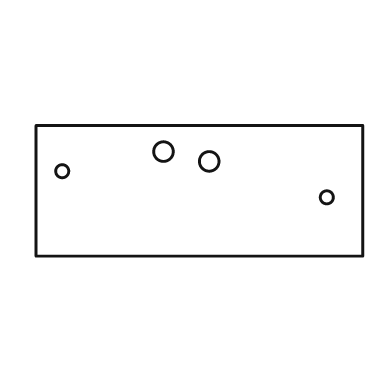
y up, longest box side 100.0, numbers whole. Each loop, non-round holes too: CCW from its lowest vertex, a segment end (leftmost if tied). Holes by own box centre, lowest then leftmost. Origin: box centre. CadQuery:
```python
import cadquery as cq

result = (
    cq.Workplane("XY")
    .moveTo(-50.0, -20.0)
    .lineTo(50.0, -20.0)
    .lineTo(50.0, 20.0)
    .lineTo(-50.0, 20.0)
    .close()
    .moveTo(39.0, -2.0)
    .circle(2.0)
    .moveTo(-42.0, 6.0)
    .circle(2.0)
    .moveTo(3.0, 9.0)
    .circle(3.0)
    .moveTo(-11.0, 12.0)
    .circle(3.0)
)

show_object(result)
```